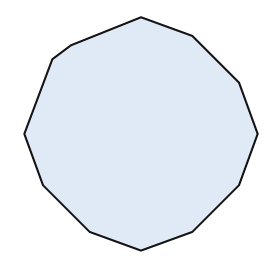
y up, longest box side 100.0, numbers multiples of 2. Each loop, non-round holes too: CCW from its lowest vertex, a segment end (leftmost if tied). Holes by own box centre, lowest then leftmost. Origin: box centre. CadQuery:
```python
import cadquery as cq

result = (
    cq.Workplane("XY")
    .moveTo(0.0, -50.0)
    .lineTo(22.0, -42.0)
    .lineTo(42.0, -22.0)
    .lineTo(50.0, 0.0)
    .lineTo(42.0, 22.0)
    .lineTo(22.0, 42.0)
    .lineTo(0.0, 50.0)
    .lineTo(-30.0, 38.0)
    .lineTo(-38.0, 32.0)
    .lineTo(-50.0, 0.0)
    .lineTo(-42.0, -22.0)
    .lineTo(-22.0, -42.0)
    .close()
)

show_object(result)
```